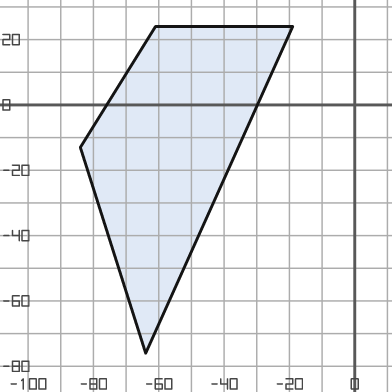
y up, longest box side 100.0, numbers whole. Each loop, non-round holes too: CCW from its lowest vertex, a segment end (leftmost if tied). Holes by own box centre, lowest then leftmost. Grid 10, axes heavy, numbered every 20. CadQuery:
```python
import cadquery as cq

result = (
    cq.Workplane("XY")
    .moveTo(-64.0, -76.0)
    .lineTo(-19.0, 24.0)
    .lineTo(-61.0, 24.0)
    .lineTo(-84.0, -13.0)
    .close()
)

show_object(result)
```